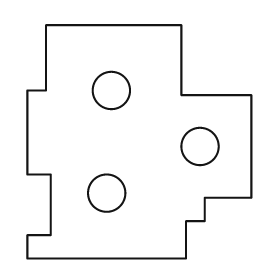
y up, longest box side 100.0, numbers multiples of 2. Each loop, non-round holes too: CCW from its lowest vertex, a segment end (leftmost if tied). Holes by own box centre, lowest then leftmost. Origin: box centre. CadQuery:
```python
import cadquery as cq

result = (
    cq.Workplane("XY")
    .moveTo(-48.0, -50.0)
    .lineTo(20.0, -50.0)
    .lineTo(20.0, -34.0)
    .lineTo(28.0, -34.0)
    .lineTo(28.0, -24.0)
    .lineTo(48.0, -24.0)
    .lineTo(48.0, 20.0)
    .lineTo(18.0, 20.0)
    .lineTo(18.0, 50.0)
    .lineTo(-40.0, 50.0)
    .lineTo(-40.0, 22.0)
    .lineTo(-48.0, 22.0)
    .lineTo(-48.0, -14.0)
    .lineTo(-38.0, -14.0)
    .lineTo(-38.0, -40.0)
    .lineTo(-48.0, -40.0)
    .close()
    .moveTo(-14.0, -22.0)
    .circle(8.0)
    .moveTo(26.0, -2.0)
    .circle(8.0)
    .moveTo(-12.0, 22.0)
    .circle(8.0)
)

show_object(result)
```